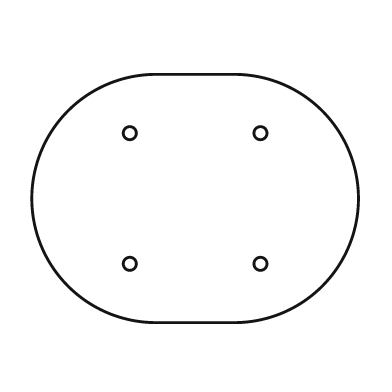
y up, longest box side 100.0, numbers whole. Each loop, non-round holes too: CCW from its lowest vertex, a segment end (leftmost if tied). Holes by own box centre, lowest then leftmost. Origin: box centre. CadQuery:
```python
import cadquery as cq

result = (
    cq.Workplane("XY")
    .moveTo(-12.0, -38.0)
    .lineTo(12.0, -38.0)
    .threePointArc((50.0, 0.0), (12.0, 38.0))
    .lineTo(-12.0, 38.0)
    .threePointArc((-50.0, 0.0), (-12.0, -38.0))
    .close()
    .moveTo(-20.0, -20.0)
    .circle(2.0)
    .moveTo(20.0, -20.0)
    .circle(2.0)
    .moveTo(-20.0, 20.0)
    .circle(2.0)
    .moveTo(20.0, 20.0)
    .circle(2.0)
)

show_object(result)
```